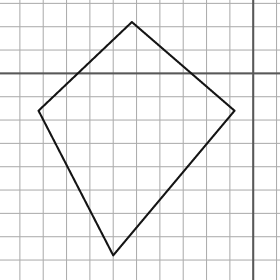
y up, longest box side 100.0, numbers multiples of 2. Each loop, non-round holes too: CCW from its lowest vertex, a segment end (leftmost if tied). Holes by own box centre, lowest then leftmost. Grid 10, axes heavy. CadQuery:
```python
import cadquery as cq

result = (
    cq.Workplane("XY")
    .moveTo(-60.0, -78.0)
    .lineTo(-8.0, -16.0)
    .lineTo(-52.0, 22.0)
    .lineTo(-92.0, -16.0)
    .close()
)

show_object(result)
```